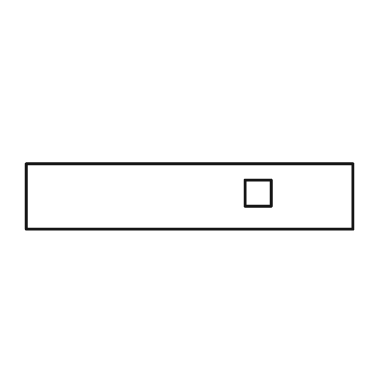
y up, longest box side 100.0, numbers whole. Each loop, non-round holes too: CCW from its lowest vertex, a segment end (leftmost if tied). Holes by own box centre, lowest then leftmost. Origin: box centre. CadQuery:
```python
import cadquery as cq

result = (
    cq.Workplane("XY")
    .moveTo(-50.0, -10.0)
    .lineTo(50.0, -10.0)
    .lineTo(50.0, 10.0)
    .lineTo(-50.0, 10.0)
    .close()
    .moveTo(17.0, -3.0)
    .lineTo(25.0, -3.0)
    .lineTo(25.0, 5.0)
    .lineTo(17.0, 5.0)
    .close()
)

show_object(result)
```